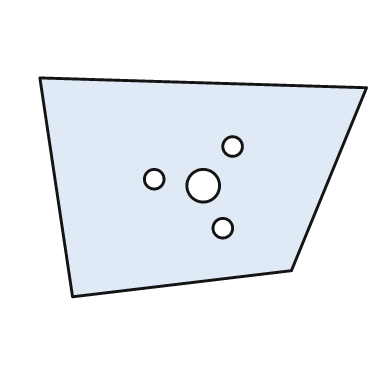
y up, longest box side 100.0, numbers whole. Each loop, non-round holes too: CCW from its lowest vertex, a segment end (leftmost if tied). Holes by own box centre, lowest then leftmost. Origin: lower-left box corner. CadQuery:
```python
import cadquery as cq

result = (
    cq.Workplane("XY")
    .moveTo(10.0, 0.0)
    .lineTo(77.0, 8.0)
    .lineTo(100.0, 64.0)
    .lineTo(0.0, 67.0)
    .close()
    .moveTo(56.0, 21.0)
    .circle(3.0)
    .moveTo(50.0, 34.0)
    .circle(5.0)
    .moveTo(35.0, 36.0)
    .circle(3.0)
    .moveTo(59.0, 46.0)
    .circle(3.0)
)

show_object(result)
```